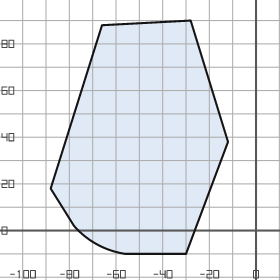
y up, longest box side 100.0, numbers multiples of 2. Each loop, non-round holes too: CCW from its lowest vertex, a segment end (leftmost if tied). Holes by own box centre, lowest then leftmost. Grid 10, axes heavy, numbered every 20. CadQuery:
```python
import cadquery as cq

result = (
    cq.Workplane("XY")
    .moveTo(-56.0, -10.0)
    .lineTo(-30.0, -10.0)
    .lineTo(-12.0, 38.0)
    .lineTo(-28.0, 90.0)
    .lineTo(-66.0, 88.0)
    .lineTo(-88.0, 18.0)
    .lineTo(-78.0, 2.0)
    .threePointArc((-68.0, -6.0), (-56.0, -10.0))
    .close()
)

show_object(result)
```